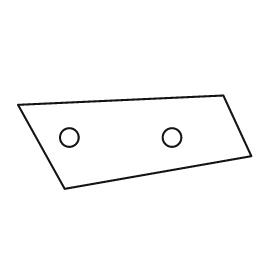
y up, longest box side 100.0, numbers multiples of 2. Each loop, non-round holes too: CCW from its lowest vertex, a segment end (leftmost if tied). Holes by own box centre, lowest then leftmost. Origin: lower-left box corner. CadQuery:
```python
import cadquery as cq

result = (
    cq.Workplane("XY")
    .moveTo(20.0, 0.0)
    .lineTo(100.0, 14.0)
    .lineTo(88.0, 40.0)
    .lineTo(0.0, 36.0)
    .close()
    .moveTo(22.0, 22.0)
    .circle(4.0)
    .moveTo(66.0, 22.0)
    .circle(4.0)
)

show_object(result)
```